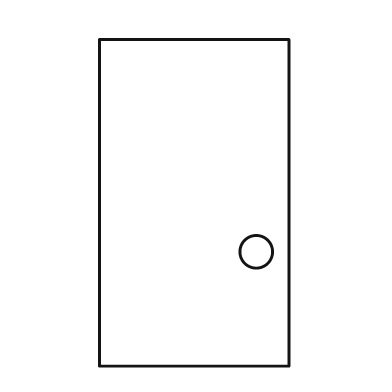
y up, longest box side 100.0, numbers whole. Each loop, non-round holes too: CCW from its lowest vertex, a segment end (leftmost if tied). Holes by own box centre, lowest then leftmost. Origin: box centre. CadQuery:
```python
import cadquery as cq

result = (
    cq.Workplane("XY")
    .moveTo(-29.0, -50.0)
    .lineTo(29.0, -50.0)
    .lineTo(29.0, 50.0)
    .lineTo(-29.0, 50.0)
    .close()
    .moveTo(19.0, -15.0)
    .circle(5.0)
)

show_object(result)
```